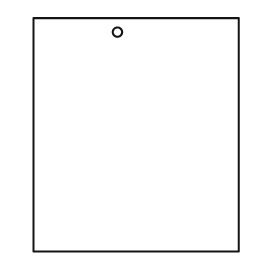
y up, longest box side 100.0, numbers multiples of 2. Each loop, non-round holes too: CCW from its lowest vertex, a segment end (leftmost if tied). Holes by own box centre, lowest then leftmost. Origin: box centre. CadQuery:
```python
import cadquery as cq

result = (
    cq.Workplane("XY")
    .moveTo(-44.0, -50.0)
    .lineTo(44.0, -50.0)
    .lineTo(44.0, 50.0)
    .lineTo(-44.0, 50.0)
    .close()
    .moveTo(-8.0, 44.0)
    .circle(2.0)
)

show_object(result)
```